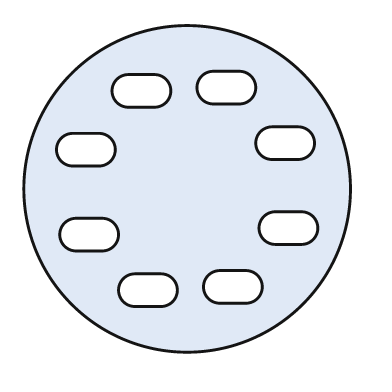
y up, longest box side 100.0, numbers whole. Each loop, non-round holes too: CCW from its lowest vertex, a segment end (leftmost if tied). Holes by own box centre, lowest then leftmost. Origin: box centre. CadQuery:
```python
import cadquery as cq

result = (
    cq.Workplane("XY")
    .moveTo(0.0, 0.0)
    .circle(50.0)
    .moveTo(-16.0, -36.0)
    .lineTo(-8.0, -36.0)
    .threePointArc((-3.0, -31.0), (-8.0, -26.0))
    .lineTo(-16.0, -26.0)
    .threePointArc((-21.0, -31.0), (-16.0, -36.0))
    .close()
    .moveTo(10.0, -35.0)
    .lineTo(18.0, -35.0)
    .threePointArc((23.0, -30.0), (18.0, -25.0))
    .lineTo(10.0, -25.0)
    .threePointArc((5.0, -30.0), (10.0, -35.0))
    .close()
    .moveTo(-34.0, -19.0)
    .lineTo(-26.0, -19.0)
    .threePointArc((-21.0, -14.0), (-26.0, -9.0))
    .lineTo(-34.0, -9.0)
    .threePointArc((-39.0, -14.0), (-34.0, -19.0))
    .close()
    .moveTo(27.0, -17.0)
    .lineTo(35.0, -17.0)
    .threePointArc((40.0, -12.0), (35.0, -7.0))
    .lineTo(27.0, -7.0)
    .threePointArc((22.0, -12.0), (27.0, -17.0))
    .close()
    .moveTo(-35.0, 7.0)
    .lineTo(-27.0, 7.0)
    .threePointArc((-22.0, 12.0), (-27.0, 17.0))
    .lineTo(-35.0, 17.0)
    .threePointArc((-40.0, 12.0), (-35.0, 7.0))
    .close()
    .moveTo(26.0, 9.0)
    .lineTo(34.0, 9.0)
    .threePointArc((39.0, 14.0), (34.0, 19.0))
    .lineTo(26.0, 19.0)
    .threePointArc((21.0, 14.0), (26.0, 9.0))
    .close()
    .moveTo(-18.0, 25.0)
    .lineTo(-10.0, 25.0)
    .threePointArc((-5.0, 30.0), (-10.0, 35.0))
    .lineTo(-18.0, 35.0)
    .threePointArc((-23.0, 30.0), (-18.0, 25.0))
    .close()
    .moveTo(8.0, 26.0)
    .lineTo(16.0, 26.0)
    .threePointArc((21.0, 31.0), (16.0, 36.0))
    .lineTo(8.0, 36.0)
    .threePointArc((3.0, 31.0), (8.0, 26.0))
    .close()
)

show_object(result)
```